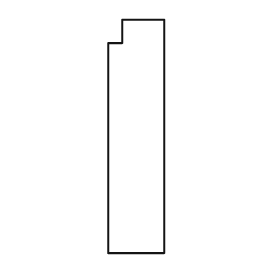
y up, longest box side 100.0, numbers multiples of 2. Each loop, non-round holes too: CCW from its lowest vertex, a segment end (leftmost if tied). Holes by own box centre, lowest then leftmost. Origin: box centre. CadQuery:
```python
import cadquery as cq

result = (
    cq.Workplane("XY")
    .moveTo(-12.0, -50.0)
    .lineTo(12.0, -50.0)
    .lineTo(12.0, 50.0)
    .lineTo(-6.0, 50.0)
    .lineTo(-6.0, 40.0)
    .lineTo(-12.0, 40.0)
    .close()
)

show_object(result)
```